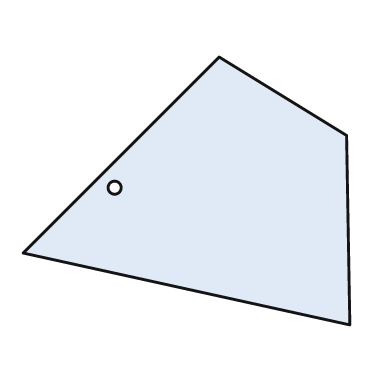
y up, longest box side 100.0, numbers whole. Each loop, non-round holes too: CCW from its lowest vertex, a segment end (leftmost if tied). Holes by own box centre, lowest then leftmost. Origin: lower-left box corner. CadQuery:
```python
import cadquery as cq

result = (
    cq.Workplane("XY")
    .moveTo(100.0, 0.0)
    .lineTo(99.0, 58.0)
    .lineTo(60.0, 82.0)
    .lineTo(0.0, 22.0)
    .close()
    .moveTo(28.0, 42.0)
    .circle(2.0)
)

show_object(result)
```